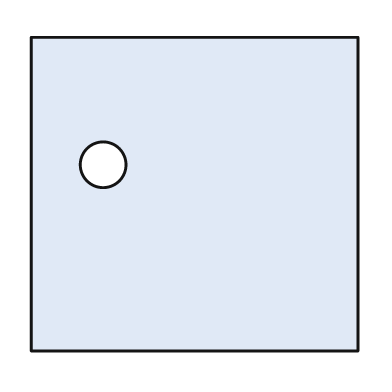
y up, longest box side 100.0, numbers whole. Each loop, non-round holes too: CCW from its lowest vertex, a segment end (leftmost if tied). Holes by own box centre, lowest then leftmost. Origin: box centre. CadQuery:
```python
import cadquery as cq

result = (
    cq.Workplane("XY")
    .moveTo(-50.0, -48.0)
    .lineTo(50.0, -48.0)
    .lineTo(50.0, 48.0)
    .lineTo(-50.0, 48.0)
    .close()
    .moveTo(-28.0, 9.0)
    .circle(7.0)
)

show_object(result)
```